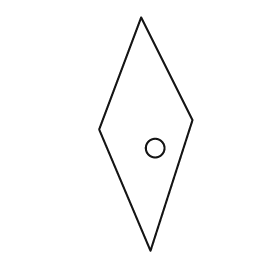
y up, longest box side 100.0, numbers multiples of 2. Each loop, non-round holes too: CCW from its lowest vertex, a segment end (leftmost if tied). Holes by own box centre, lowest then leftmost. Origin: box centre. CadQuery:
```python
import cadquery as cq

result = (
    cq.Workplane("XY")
    .moveTo(2.0, -50.0)
    .lineTo(20.0, 6.0)
    .lineTo(-2.0, 50.0)
    .lineTo(-20.0, 2.0)
    .close()
    .moveTo(4.0, -6.0)
    .circle(4.0)
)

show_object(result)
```